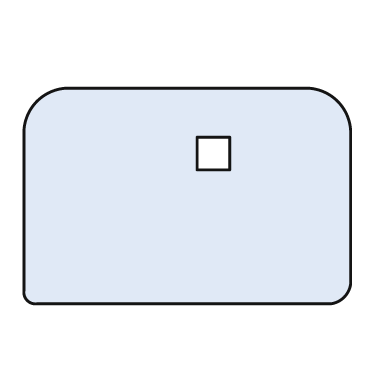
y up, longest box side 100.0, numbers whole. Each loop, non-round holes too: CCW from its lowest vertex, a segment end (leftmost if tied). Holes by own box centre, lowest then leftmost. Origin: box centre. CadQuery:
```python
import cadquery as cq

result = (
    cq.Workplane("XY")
    .moveTo(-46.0, -33.0)
    .lineTo(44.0, -33.0)
    .threePointArc((48.0, -31.0), (50.0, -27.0))
    .lineTo(50.0, 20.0)
    .threePointArc((46.0, 29.0), (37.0, 33.0))
    .lineTo(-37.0, 33.0)
    .threePointArc((-46.0, 29.0), (-50.0, 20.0))
    .lineTo(-50.0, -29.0)
    .threePointArc((-49.0, -32.0), (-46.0, -33.0))
    .close()
    .moveTo(3.0, 8.0)
    .lineTo(13.0, 8.0)
    .lineTo(13.0, 18.0)
    .lineTo(3.0, 18.0)
    .close()
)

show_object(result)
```